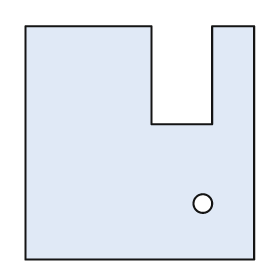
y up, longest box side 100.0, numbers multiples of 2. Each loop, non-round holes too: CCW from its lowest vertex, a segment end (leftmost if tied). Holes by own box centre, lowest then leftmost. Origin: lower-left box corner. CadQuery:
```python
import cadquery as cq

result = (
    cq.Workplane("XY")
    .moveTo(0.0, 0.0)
    .lineTo(98.0, 0.0)
    .lineTo(98.0, 100.0)
    .lineTo(80.0, 100.0)
    .lineTo(80.0, 58.0)
    .lineTo(54.0, 58.0)
    .lineTo(54.0, 100.0)
    .lineTo(0.0, 100.0)
    .close()
    .moveTo(76.0, 24.0)
    .circle(4.0)
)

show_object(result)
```